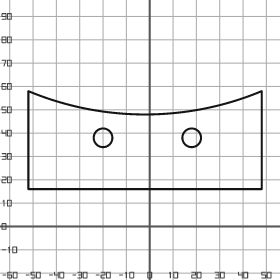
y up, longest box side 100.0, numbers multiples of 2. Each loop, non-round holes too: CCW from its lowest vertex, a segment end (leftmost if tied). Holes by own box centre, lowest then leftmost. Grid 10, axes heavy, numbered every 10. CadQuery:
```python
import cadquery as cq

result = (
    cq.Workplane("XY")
    .moveTo(-52.0, 16.0)
    .lineTo(48.0, 16.0)
    .lineTo(48.0, 58.0)
    .threePointArc((-2.0, 48.0), (-52.0, 58.0))
    .close()
    .moveTo(-20.0, 38.0)
    .circle(4.0)
    .moveTo(18.0, 38.0)
    .circle(4.0)
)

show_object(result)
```